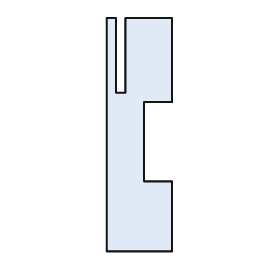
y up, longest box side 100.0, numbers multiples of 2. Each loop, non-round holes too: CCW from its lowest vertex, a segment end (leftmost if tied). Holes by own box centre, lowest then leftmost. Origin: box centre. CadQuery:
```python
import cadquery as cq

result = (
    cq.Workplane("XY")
    .moveTo(-14.0, -50.0)
    .lineTo(14.0, -50.0)
    .lineTo(14.0, -20.0)
    .lineTo(2.0, -20.0)
    .lineTo(2.0, 14.0)
    .lineTo(14.0, 14.0)
    .lineTo(14.0, 50.0)
    .lineTo(-6.0, 50.0)
    .lineTo(-6.0, 18.0)
    .lineTo(-10.0, 18.0)
    .lineTo(-10.0, 50.0)
    .lineTo(-14.0, 50.0)
    .close()
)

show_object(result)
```